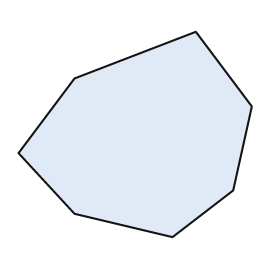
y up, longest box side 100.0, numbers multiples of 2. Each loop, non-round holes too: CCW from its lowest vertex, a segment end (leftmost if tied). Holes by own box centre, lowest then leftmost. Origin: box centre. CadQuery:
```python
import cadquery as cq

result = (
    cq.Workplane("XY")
    .moveTo(16.0, -44.0)
    .lineTo(42.0, -24.0)
    .lineTo(50.0, 12.0)
    .lineTo(26.0, 44.0)
    .lineTo(-26.0, 24.0)
    .lineTo(-50.0, -8.0)
    .lineTo(-26.0, -34.0)
    .close()
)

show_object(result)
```